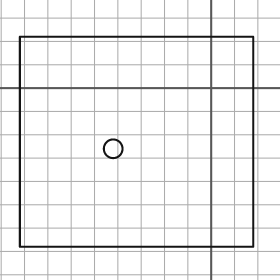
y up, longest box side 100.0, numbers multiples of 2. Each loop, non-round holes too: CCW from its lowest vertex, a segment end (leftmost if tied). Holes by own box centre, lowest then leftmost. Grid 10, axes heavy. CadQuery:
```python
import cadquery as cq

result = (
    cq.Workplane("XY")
    .moveTo(-82.0, -68.0)
    .lineTo(18.0, -68.0)
    .lineTo(18.0, 22.0)
    .lineTo(-82.0, 22.0)
    .close()
    .moveTo(-42.0, -26.0)
    .circle(4.0)
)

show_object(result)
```